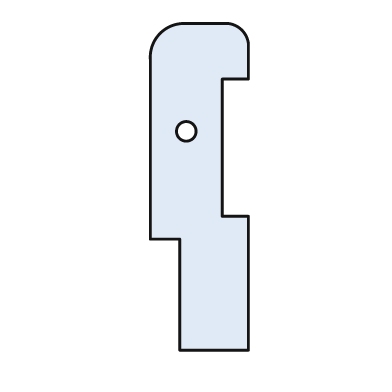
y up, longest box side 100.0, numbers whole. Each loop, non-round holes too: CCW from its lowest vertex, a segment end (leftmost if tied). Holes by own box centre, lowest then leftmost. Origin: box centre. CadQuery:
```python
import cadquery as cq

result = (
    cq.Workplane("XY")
    .moveTo(-6.0, -50.0)
    .lineTo(15.0, -50.0)
    .lineTo(15.0, -9.0)
    .lineTo(7.0, -9.0)
    .lineTo(7.0, 33.0)
    .lineTo(15.0, 33.0)
    .lineTo(15.0, 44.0)
    .threePointArc((13.0, 48.0), (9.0, 50.0))
    .lineTo(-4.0, 50.0)
    .threePointArc((-12.0, 47.0), (-15.0, 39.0))
    .lineTo(-15.0, -16.0)
    .lineTo(-6.0, -16.0)
    .close()
    .moveTo(-4.0, 17.0)
    .circle(3.0)
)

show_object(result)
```